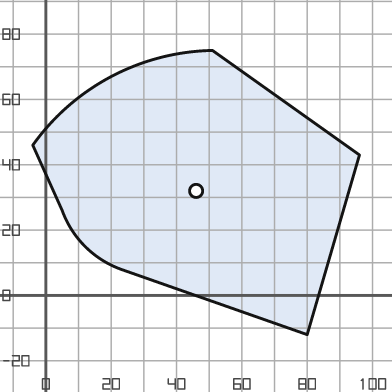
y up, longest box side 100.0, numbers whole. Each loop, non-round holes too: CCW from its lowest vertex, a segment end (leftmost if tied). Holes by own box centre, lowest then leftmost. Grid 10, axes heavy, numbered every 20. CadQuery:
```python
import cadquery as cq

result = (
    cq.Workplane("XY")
    .moveTo(80.0, -12.0)
    .lineTo(96.0, 43.0)
    .lineTo(51.0, 75.0)
    .threePointArc((20.0, 67.0), (-4.0, 46.0))
    .lineTo(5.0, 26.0)
    .threePointArc((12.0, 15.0), (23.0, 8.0))
    .close()
    .moveTo(46.0, 32.0)
    .circle(2.0)
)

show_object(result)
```